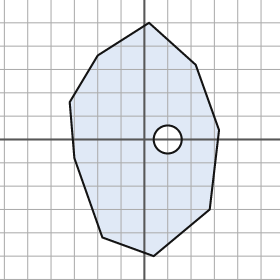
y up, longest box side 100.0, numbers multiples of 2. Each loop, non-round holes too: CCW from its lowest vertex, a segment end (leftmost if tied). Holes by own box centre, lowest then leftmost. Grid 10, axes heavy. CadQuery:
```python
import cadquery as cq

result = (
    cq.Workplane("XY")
    .moveTo(4.0, -50.0)
    .lineTo(28.0, -30.0)
    .lineTo(32.0, 4.0)
    .lineTo(22.0, 32.0)
    .lineTo(2.0, 50.0)
    .lineTo(-20.0, 36.0)
    .lineTo(-32.0, 16.0)
    .lineTo(-30.0, -8.0)
    .lineTo(-18.0, -42.0)
    .close()
    .moveTo(10.0, 0.0)
    .circle(6.0)
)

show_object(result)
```